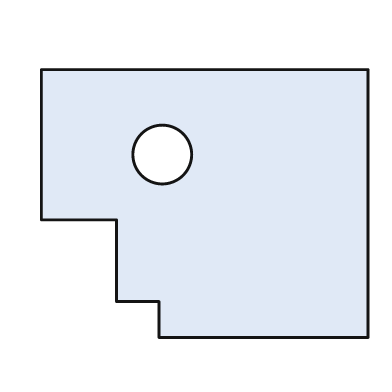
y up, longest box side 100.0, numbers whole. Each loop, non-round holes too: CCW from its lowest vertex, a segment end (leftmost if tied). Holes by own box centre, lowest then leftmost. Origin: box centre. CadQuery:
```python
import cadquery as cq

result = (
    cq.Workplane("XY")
    .moveTo(-14.0, -41.0)
    .lineTo(50.0, -41.0)
    .lineTo(50.0, 41.0)
    .lineTo(-50.0, 41.0)
    .lineTo(-50.0, -5.0)
    .lineTo(-27.0, -5.0)
    .lineTo(-27.0, -30.0)
    .lineTo(-14.0, -30.0)
    .close()
    .moveTo(-13.0, 15.0)
    .circle(9.0)
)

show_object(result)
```